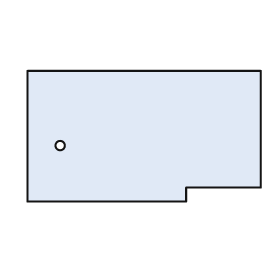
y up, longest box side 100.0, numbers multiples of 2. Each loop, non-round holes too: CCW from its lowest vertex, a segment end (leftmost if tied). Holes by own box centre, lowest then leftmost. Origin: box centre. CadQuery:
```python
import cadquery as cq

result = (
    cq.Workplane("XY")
    .moveTo(-50.0, -28.0)
    .lineTo(18.0, -28.0)
    .lineTo(18.0, -22.0)
    .lineTo(50.0, -22.0)
    .lineTo(50.0, 28.0)
    .lineTo(-50.0, 28.0)
    .close()
    .moveTo(-36.0, -4.0)
    .circle(2.0)
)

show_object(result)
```